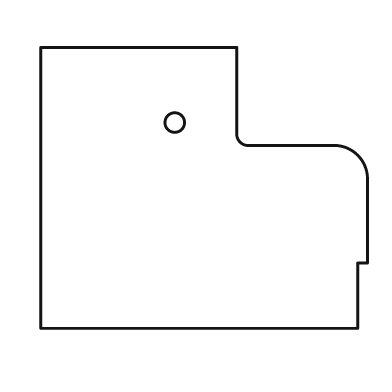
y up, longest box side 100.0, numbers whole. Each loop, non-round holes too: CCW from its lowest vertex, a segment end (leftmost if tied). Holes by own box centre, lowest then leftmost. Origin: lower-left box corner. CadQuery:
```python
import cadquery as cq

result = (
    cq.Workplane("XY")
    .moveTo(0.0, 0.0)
    .lineTo(97.0, 0.0)
    .lineTo(97.0, 20.0)
    .lineTo(100.0, 20.0)
    .lineTo(100.0, 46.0)
    .threePointArc((97.0, 53.0), (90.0, 56.0))
    .lineTo(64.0, 56.0)
    .threePointArc((61.0, 57.0), (60.0, 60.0))
    .lineTo(60.0, 86.0)
    .lineTo(0.0, 86.0)
    .close()
    .moveTo(41.0, 63.0)
    .circle(3.0)
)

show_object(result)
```